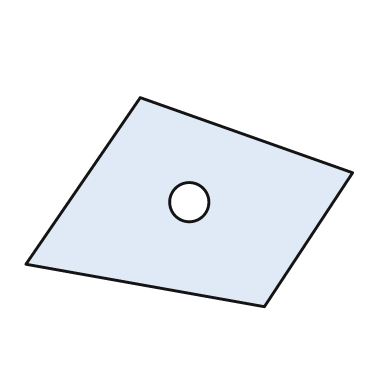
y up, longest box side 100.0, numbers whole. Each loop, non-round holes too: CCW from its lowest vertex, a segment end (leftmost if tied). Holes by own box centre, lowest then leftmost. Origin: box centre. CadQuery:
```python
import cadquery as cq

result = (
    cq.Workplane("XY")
    .moveTo(23.0, -32.0)
    .lineTo(50.0, 9.0)
    .lineTo(-15.0, 32.0)
    .lineTo(-50.0, -19.0)
    .close()
    .moveTo(0.0, 0.0)
    .circle(6.0)
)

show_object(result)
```